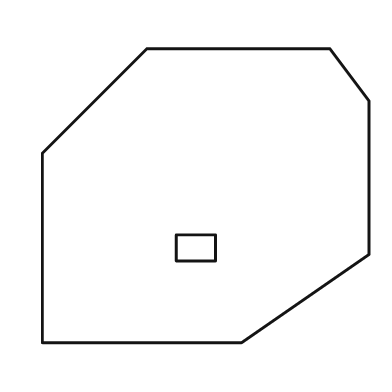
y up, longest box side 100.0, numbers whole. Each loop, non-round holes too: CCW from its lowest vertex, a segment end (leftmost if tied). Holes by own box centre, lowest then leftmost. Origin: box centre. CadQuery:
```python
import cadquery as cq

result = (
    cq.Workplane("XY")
    .moveTo(-50.0, -45.0)
    .lineTo(11.0, -45.0)
    .lineTo(50.0, -18.0)
    .lineTo(50.0, 29.0)
    .lineTo(38.0, 45.0)
    .lineTo(-18.0, 45.0)
    .lineTo(-50.0, 13.0)
    .close()
    .moveTo(-9.0, -20.0)
    .lineTo(3.0, -20.0)
    .lineTo(3.0, -12.0)
    .lineTo(-9.0, -12.0)
    .close()
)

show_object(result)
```